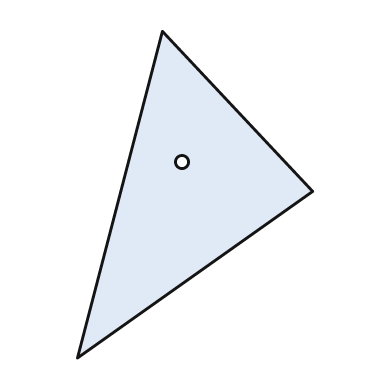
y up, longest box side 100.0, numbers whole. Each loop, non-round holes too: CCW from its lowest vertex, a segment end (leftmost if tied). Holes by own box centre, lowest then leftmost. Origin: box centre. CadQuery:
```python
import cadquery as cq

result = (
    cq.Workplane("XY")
    .moveTo(-36.0, -50.0)
    .lineTo(36.0, 1.0)
    .lineTo(-10.0, 50.0)
    .close()
    .moveTo(-4.0, 10.0)
    .circle(2.0)
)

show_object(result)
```